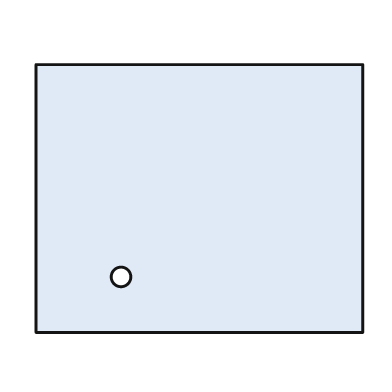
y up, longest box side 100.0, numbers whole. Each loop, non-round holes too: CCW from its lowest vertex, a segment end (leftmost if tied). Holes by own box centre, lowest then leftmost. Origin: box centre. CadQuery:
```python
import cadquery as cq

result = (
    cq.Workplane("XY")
    .moveTo(-50.0, -41.0)
    .lineTo(50.0, -41.0)
    .lineTo(50.0, 41.0)
    .lineTo(-50.0, 41.0)
    .close()
    .moveTo(-24.0, -24.0)
    .circle(3.0)
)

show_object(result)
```